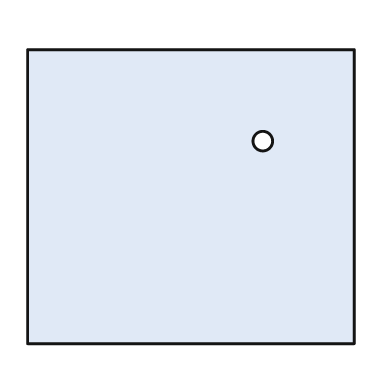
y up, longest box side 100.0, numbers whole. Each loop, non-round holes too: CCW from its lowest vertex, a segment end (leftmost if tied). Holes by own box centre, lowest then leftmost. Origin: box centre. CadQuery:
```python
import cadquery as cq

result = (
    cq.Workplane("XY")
    .moveTo(-50.0, -45.0)
    .lineTo(50.0, -45.0)
    .lineTo(50.0, 45.0)
    .lineTo(-50.0, 45.0)
    .close()
    .moveTo(22.0, 17.0)
    .circle(3.0)
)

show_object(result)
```